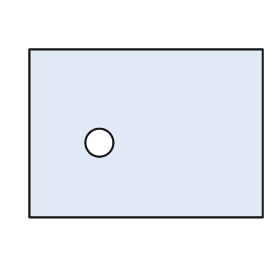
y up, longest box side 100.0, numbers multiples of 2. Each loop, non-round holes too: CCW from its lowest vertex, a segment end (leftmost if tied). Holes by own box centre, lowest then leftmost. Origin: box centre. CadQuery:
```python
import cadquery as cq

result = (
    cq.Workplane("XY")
    .moveTo(-50.0, -36.0)
    .lineTo(50.0, -36.0)
    .lineTo(50.0, 36.0)
    .lineTo(-50.0, 36.0)
    .close()
    .moveTo(-20.0, -4.0)
    .circle(6.0)
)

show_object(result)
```